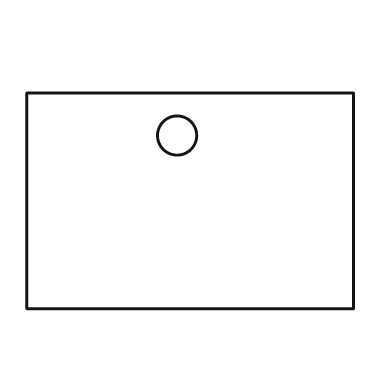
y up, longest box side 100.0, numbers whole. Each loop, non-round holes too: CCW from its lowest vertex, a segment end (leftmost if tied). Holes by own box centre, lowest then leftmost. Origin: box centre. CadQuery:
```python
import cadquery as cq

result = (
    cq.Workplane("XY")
    .moveTo(-50.0, -33.0)
    .lineTo(50.0, -33.0)
    .lineTo(50.0, 33.0)
    .lineTo(-50.0, 33.0)
    .close()
    .moveTo(-4.0, 20.0)
    .circle(6.0)
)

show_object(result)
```